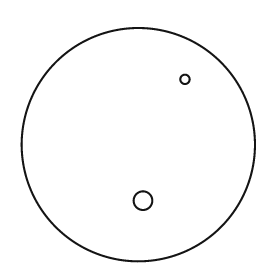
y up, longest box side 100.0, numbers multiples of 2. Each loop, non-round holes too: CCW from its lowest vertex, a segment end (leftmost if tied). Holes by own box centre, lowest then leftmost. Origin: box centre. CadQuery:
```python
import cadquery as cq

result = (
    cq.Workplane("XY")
    .moveTo(0.0, 0.0)
    .circle(50.0)
    .moveTo(2.0, -24.0)
    .circle(4.0)
    .moveTo(20.0, 28.0)
    .circle(2.0)
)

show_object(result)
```